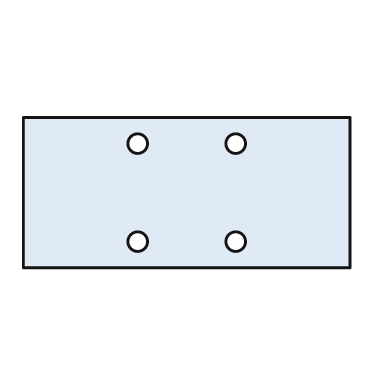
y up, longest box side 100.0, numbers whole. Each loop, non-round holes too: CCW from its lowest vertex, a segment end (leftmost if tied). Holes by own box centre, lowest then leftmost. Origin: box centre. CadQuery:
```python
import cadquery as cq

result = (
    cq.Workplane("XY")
    .moveTo(-50.0, -23.0)
    .lineTo(50.0, -23.0)
    .lineTo(50.0, 23.0)
    .lineTo(-50.0, 23.0)
    .close()
    .moveTo(-15.0, -15.0)
    .circle(3.0)
    .moveTo(15.0, -15.0)
    .circle(3.0)
    .moveTo(-15.0, 15.0)
    .circle(3.0)
    .moveTo(15.0, 15.0)
    .circle(3.0)
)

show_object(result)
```